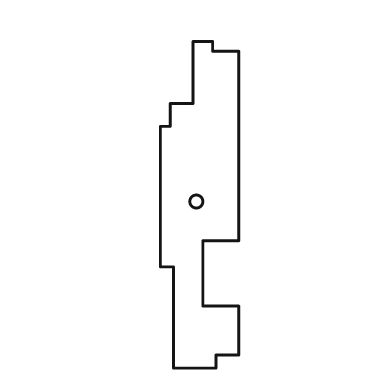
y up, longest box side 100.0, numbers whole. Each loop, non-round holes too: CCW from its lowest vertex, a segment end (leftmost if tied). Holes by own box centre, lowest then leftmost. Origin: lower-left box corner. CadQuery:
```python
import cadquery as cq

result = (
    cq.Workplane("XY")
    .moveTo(4.0, 0.0)
    .lineTo(17.0, 0.0)
    .lineTo(17.0, 4.0)
    .lineTo(24.0, 4.0)
    .lineTo(24.0, 19.0)
    .lineTo(13.0, 19.0)
    .lineTo(13.0, 39.0)
    .lineTo(24.0, 39.0)
    .lineTo(24.0, 97.0)
    .lineTo(16.0, 97.0)
    .lineTo(16.0, 100.0)
    .lineTo(10.0, 100.0)
    .lineTo(10.0, 81.0)
    .lineTo(3.0, 81.0)
    .lineTo(3.0, 74.0)
    .lineTo(0.0, 74.0)
    .lineTo(0.0, 31.0)
    .lineTo(4.0, 31.0)
    .close()
    .moveTo(11.0, 51.0)
    .circle(2.0)
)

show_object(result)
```